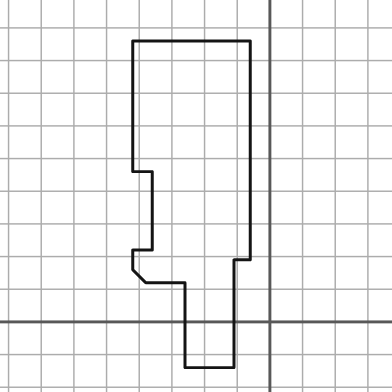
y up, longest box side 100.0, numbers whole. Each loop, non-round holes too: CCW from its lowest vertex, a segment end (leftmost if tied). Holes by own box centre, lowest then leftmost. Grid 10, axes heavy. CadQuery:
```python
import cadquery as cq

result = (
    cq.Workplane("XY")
    .moveTo(-26.0, -14.0)
    .lineTo(-11.0, -14.0)
    .lineTo(-11.0, 19.0)
    .lineTo(-6.0, 19.0)
    .lineTo(-6.0, 86.0)
    .lineTo(-42.0, 86.0)
    .lineTo(-42.0, 46.0)
    .lineTo(-36.0, 46.0)
    .lineTo(-36.0, 22.0)
    .lineTo(-42.0, 22.0)
    .lineTo(-42.0, 16.0)
    .lineTo(-38.0, 12.0)
    .lineTo(-26.0, 12.0)
    .close()
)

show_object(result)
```